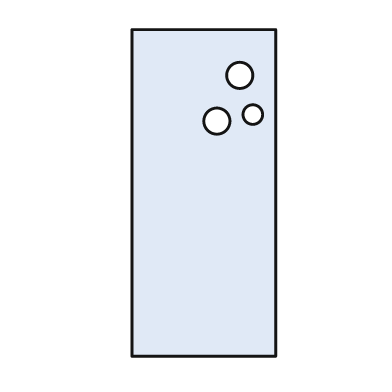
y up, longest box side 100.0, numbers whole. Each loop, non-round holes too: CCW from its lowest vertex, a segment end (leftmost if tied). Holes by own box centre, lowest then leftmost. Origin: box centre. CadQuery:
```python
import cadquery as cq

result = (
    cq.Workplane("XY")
    .moveTo(-22.0, -50.0)
    .lineTo(22.0, -50.0)
    .lineTo(22.0, 50.0)
    .lineTo(-22.0, 50.0)
    .close()
    .moveTo(4.0, 22.0)
    .circle(4.0)
    .moveTo(15.0, 24.0)
    .circle(3.0)
    .moveTo(11.0, 36.0)
    .circle(4.0)
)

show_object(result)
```